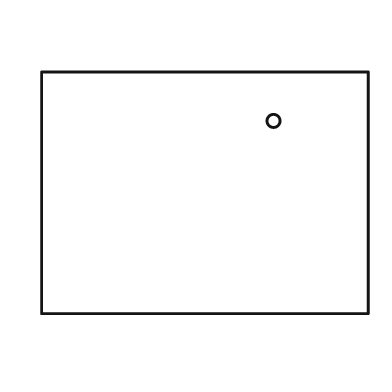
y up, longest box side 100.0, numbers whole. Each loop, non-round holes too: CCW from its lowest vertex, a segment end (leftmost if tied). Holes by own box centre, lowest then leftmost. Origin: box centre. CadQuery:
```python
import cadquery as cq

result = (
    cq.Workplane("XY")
    .moveTo(-50.0, -37.0)
    .lineTo(50.0, -37.0)
    .lineTo(50.0, 37.0)
    .lineTo(-50.0, 37.0)
    .close()
    .moveTo(21.0, 22.0)
    .circle(2.0)
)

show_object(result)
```